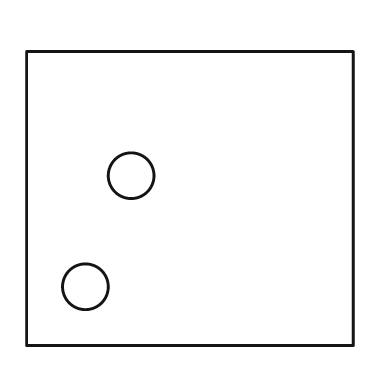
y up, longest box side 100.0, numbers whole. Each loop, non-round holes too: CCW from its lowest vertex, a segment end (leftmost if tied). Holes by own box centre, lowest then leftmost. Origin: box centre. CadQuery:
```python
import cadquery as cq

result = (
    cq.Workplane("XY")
    .moveTo(-50.0, -45.0)
    .lineTo(50.0, -45.0)
    .lineTo(50.0, 45.0)
    .lineTo(-50.0, 45.0)
    .close()
    .moveTo(-32.0, -27.0)
    .circle(7.0)
    .moveTo(-18.0, 7.0)
    .circle(7.0)
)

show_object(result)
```